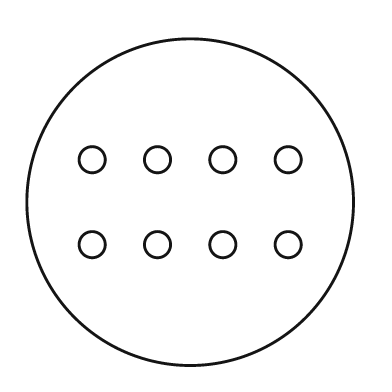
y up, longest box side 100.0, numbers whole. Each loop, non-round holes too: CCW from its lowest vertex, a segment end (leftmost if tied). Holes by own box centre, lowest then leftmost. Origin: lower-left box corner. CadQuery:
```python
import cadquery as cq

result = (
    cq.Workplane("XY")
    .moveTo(50.0, 50.0)
    .circle(50.0)
    .moveTo(20.0, 37.0)
    .circle(4.0)
    .moveTo(40.0, 37.0)
    .circle(4.0)
    .moveTo(60.0, 37.0)
    .circle(4.0)
    .moveTo(80.0, 37.0)
    .circle(4.0)
    .moveTo(20.0, 63.0)
    .circle(4.0)
    .moveTo(40.0, 63.0)
    .circle(4.0)
    .moveTo(60.0, 63.0)
    .circle(4.0)
    .moveTo(80.0, 63.0)
    .circle(4.0)
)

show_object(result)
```